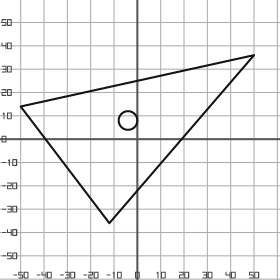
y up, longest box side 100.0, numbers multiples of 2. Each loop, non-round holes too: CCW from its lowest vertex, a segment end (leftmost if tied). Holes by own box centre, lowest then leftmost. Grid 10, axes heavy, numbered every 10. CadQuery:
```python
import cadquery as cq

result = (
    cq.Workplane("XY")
    .moveTo(-12.0, -36.0)
    .lineTo(50.0, 36.0)
    .lineTo(-50.0, 14.0)
    .close()
    .moveTo(-4.0, 8.0)
    .circle(4.0)
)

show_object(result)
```